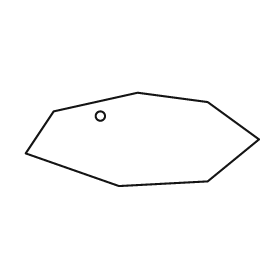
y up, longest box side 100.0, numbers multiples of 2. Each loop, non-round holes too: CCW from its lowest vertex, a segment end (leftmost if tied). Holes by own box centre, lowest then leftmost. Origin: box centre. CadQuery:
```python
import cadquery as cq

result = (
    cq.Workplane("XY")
    .moveTo(-10.0, -20.0)
    .lineTo(28.0, -18.0)
    .lineTo(50.0, 0.0)
    .lineTo(28.0, 16.0)
    .lineTo(-2.0, 20.0)
    .lineTo(-38.0, 12.0)
    .lineTo(-50.0, -6.0)
    .close()
    .moveTo(-18.0, 10.0)
    .circle(2.0)
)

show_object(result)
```